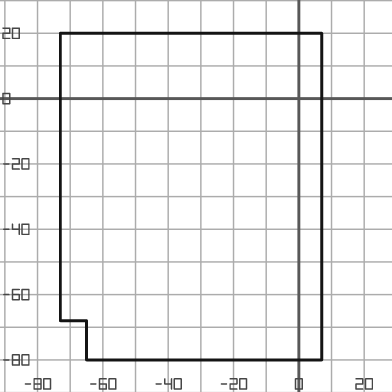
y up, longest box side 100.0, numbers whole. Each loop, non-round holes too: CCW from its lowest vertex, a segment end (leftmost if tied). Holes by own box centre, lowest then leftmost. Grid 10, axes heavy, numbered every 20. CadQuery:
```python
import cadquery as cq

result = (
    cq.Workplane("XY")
    .moveTo(-65.0, -80.0)
    .lineTo(7.0, -80.0)
    .lineTo(7.0, 20.0)
    .lineTo(-73.0, 20.0)
    .lineTo(-73.0, -68.0)
    .lineTo(-65.0, -68.0)
    .close()
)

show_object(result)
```